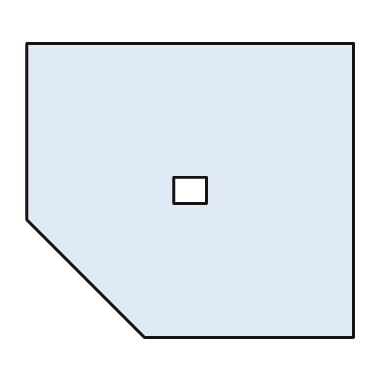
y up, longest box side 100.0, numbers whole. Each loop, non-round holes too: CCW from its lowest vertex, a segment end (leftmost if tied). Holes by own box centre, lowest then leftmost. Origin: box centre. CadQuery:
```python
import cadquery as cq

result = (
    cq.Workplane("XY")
    .moveTo(-14.0, -45.0)
    .lineTo(50.0, -45.0)
    .lineTo(50.0, 45.0)
    .lineTo(-50.0, 45.0)
    .lineTo(-50.0, -9.0)
    .close()
    .moveTo(-5.0, -4.0)
    .lineTo(5.0, -4.0)
    .lineTo(5.0, 4.0)
    .lineTo(-5.0, 4.0)
    .close()
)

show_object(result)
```